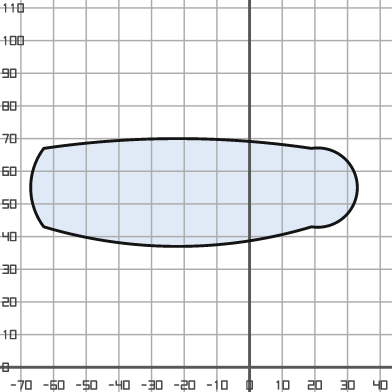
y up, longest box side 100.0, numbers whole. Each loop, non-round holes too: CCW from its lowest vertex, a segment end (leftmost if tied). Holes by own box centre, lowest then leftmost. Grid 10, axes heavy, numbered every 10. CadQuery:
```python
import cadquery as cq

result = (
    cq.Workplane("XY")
    .moveTo(-63.0, 43.0)
    .threePointArc((-22.0, 37.0), (19.0, 43.0))
    .threePointArc((33.0, 55.0), (19.0, 67.0))
    .threePointArc((-22.0, 70.0), (-63.0, 67.0))
    .threePointArc((-67.0, 55.0), (-63.0, 43.0))
    .close()
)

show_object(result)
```